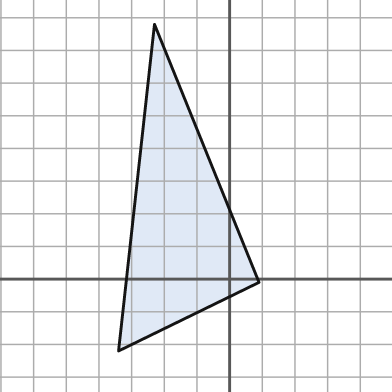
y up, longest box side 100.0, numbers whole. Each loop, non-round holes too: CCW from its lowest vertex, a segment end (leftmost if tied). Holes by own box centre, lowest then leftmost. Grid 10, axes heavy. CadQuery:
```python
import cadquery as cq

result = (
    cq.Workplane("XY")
    .moveTo(-34.0, -22.0)
    .lineTo(9.0, -1.0)
    .lineTo(-23.0, 78.0)
    .close()
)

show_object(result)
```